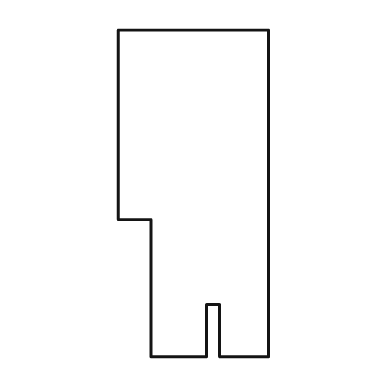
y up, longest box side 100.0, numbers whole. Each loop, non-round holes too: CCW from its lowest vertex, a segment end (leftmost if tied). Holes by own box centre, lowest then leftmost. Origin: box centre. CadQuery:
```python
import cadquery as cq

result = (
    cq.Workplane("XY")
    .moveTo(-13.0, -50.0)
    .lineTo(4.0, -50.0)
    .lineTo(4.0, -34.0)
    .lineTo(8.0, -34.0)
    .lineTo(8.0, -50.0)
    .lineTo(23.0, -50.0)
    .lineTo(23.0, 50.0)
    .lineTo(-23.0, 50.0)
    .lineTo(-23.0, -8.0)
    .lineTo(-13.0, -8.0)
    .close()
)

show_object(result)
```